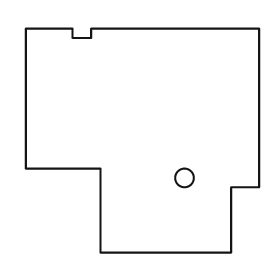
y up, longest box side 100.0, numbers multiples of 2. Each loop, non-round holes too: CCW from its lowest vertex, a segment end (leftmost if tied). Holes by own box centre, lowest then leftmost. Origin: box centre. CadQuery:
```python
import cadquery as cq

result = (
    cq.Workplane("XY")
    .moveTo(-18.0, -48.0)
    .lineTo(38.0, -48.0)
    .lineTo(38.0, -20.0)
    .lineTo(50.0, -20.0)
    .lineTo(50.0, 48.0)
    .lineTo(-22.0, 48.0)
    .lineTo(-22.0, 44.0)
    .lineTo(-30.0, 44.0)
    .lineTo(-30.0, 48.0)
    .lineTo(-50.0, 48.0)
    .lineTo(-50.0, -12.0)
    .lineTo(-18.0, -12.0)
    .close()
    .moveTo(18.0, -16.0)
    .circle(4.0)
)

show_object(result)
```